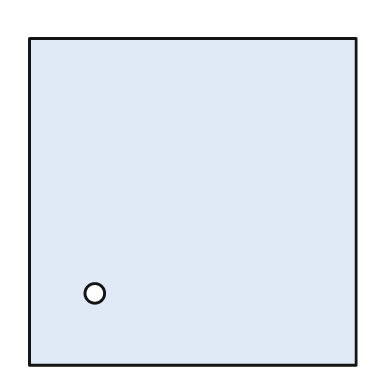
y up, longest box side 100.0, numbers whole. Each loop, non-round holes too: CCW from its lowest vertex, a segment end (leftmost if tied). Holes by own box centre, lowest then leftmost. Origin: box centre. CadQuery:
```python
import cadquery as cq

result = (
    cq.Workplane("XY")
    .moveTo(-50.0, -50.0)
    .lineTo(50.0, -50.0)
    .lineTo(50.0, 50.0)
    .lineTo(-50.0, 50.0)
    .close()
    .moveTo(-30.0, -28.0)
    .circle(3.0)
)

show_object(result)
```